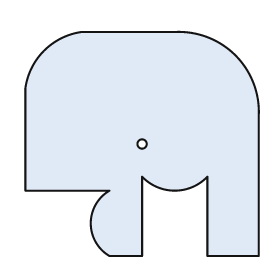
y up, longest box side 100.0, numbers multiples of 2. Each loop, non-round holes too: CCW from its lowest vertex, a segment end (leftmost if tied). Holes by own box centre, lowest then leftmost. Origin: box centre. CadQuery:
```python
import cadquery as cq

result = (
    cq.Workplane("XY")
    .moveTo(-14.0, -48.0)
    .lineTo(0.0, -48.0)
    .lineTo(0.0, -14.0)
    .threePointArc((14.0, -20.0), (28.0, -14.0))
    .lineTo(28.0, -48.0)
    .lineTo(50.0, -48.0)
    .lineTo(50.0, 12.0)
    .threePointArc((40.0, 38.0), (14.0, 48.0))
    .lineTo(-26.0, 48.0)
    .threePointArc((-42.0, 40.0), (-50.0, 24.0))
    .lineTo(-50.0, -20.0)
    .lineTo(-14.0, -20.0)
    .threePointArc((-22.0, -34.0), (-14.0, -48.0))
    .close()
    .moveTo(0.0, 0.0)
    .circle(2.0)
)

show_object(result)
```